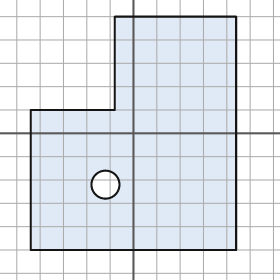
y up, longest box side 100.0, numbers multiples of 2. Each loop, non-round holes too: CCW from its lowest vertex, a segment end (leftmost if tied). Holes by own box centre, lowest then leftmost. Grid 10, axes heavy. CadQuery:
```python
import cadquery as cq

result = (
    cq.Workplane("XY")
    .moveTo(-44.0, -50.0)
    .lineTo(44.0, -50.0)
    .lineTo(44.0, 50.0)
    .lineTo(-8.0, 50.0)
    .lineTo(-8.0, 10.0)
    .lineTo(-44.0, 10.0)
    .close()
    .moveTo(-12.0, -22.0)
    .circle(6.0)
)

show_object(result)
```